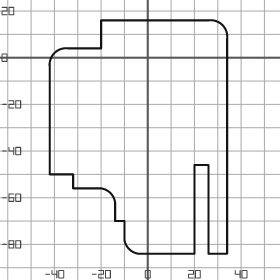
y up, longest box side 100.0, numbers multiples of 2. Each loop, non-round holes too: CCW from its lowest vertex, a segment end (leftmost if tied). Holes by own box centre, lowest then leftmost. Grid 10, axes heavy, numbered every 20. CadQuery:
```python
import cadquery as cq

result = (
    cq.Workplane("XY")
    .moveTo(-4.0, -84.0)
    .lineTo(20.0, -84.0)
    .lineTo(20.0, -46.0)
    .lineTo(26.0, -46.0)
    .lineTo(26.0, -84.0)
    .lineTo(34.0, -84.0)
    .lineTo(34.0, 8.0)
    .threePointArc((32.0, 14.0), (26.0, 16.0))
    .lineTo(-20.0, 16.0)
    .lineTo(-20.0, 4.0)
    .lineTo(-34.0, 4.0)
    .threePointArc((-40.0, 2.0), (-42.0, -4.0))
    .lineTo(-42.0, -50.0)
    .lineTo(-32.0, -50.0)
    .lineTo(-32.0, -56.0)
    .lineTo(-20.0, -56.0)
    .threePointArc((-16.0, -58.0), (-14.0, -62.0))
    .lineTo(-14.0, -70.0)
    .lineTo(-10.0, -70.0)
    .lineTo(-10.0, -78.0)
    .threePointArc((-8.0, -82.0), (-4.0, -84.0))
    .close()
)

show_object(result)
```